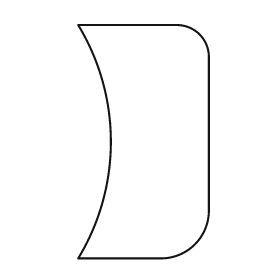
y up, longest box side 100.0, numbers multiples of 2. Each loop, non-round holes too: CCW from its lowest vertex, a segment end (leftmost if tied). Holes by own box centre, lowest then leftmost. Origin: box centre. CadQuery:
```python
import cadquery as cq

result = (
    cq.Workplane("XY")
    .moveTo(-28.0, -50.0)
    .lineTo(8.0, -50.0)
    .threePointArc((22.0, -44.0), (28.0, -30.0))
    .lineTo(28.0, 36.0)
    .threePointArc((24.0, 46.0), (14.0, 50.0))
    .lineTo(-28.0, 50.0)
    .threePointArc((-14.0, 0.0), (-28.0, -50.0))
    .close()
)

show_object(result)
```